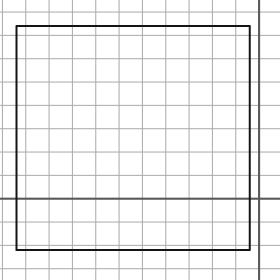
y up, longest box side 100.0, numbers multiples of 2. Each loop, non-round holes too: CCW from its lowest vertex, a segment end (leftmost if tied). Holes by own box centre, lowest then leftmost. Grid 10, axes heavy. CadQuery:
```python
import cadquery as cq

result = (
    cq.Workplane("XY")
    .moveTo(-104.0, -22.0)
    .lineTo(-4.0, -22.0)
    .lineTo(-4.0, 74.0)
    .lineTo(-104.0, 74.0)
    .close()
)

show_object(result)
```